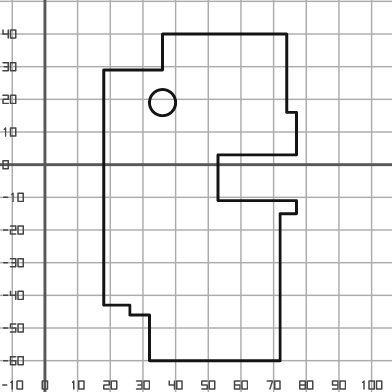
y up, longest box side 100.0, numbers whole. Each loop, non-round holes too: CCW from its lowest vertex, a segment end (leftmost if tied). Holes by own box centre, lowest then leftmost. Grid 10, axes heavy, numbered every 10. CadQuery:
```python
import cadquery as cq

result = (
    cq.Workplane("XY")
    .moveTo(32.0, -60.0)
    .lineTo(72.0, -60.0)
    .lineTo(72.0, -15.0)
    .lineTo(77.0, -15.0)
    .lineTo(77.0, -11.0)
    .lineTo(53.0, -11.0)
    .lineTo(53.0, 3.0)
    .lineTo(77.0, 3.0)
    .lineTo(77.0, 16.0)
    .lineTo(74.0, 16.0)
    .lineTo(74.0, 40.0)
    .lineTo(36.0, 40.0)
    .lineTo(36.0, 29.0)
    .lineTo(18.0, 29.0)
    .lineTo(18.0, -43.0)
    .lineTo(26.0, -43.0)
    .lineTo(26.0, -46.0)
    .lineTo(32.0, -46.0)
    .close()
    .moveTo(36.0, 19.0)
    .circle(4.0)
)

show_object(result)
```